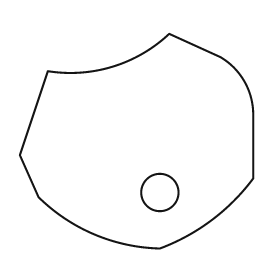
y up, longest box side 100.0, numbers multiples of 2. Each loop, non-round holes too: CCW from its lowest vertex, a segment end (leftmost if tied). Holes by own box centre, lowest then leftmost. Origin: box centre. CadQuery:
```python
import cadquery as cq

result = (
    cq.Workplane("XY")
    .moveTo(10.0, -46.0)
    .threePointArc((32.0, -34.0), (50.0, -16.0))
    .lineTo(50.0, 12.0)
    .threePointArc((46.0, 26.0), (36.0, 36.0))
    .lineTo(14.0, 46.0)
    .threePointArc((-10.0, 32.0), (-38.0, 30.0))
    .lineTo(-50.0, -6.0)
    .lineTo(-42.0, -24.0)
    .threePointArc((-18.0, -40.0), (10.0, -46.0))
    .close()
    .moveTo(10.0, -22.0)
    .circle(8.0)
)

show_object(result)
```